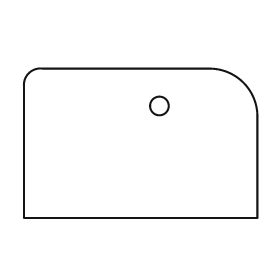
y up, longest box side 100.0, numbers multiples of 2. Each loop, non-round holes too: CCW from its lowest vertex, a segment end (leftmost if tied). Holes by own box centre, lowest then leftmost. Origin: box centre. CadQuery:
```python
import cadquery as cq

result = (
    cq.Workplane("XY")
    .moveTo(-50.0, -32.0)
    .lineTo(50.0, -32.0)
    .lineTo(50.0, 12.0)
    .threePointArc((44.0, 26.0), (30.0, 32.0))
    .lineTo(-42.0, 32.0)
    .threePointArc((-48.0, 30.0), (-50.0, 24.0))
    .close()
    .moveTo(8.0, 16.0)
    .circle(4.0)
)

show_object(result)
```